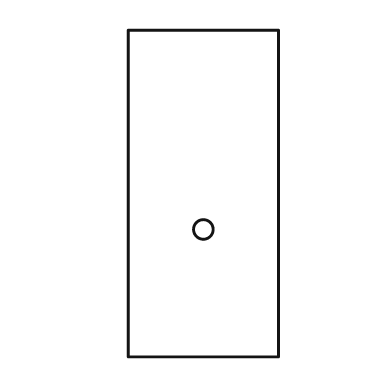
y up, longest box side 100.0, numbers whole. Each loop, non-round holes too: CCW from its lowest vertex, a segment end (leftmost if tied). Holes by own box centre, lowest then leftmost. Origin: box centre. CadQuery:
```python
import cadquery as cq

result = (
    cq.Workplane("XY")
    .moveTo(-23.0, -50.0)
    .lineTo(23.0, -50.0)
    .lineTo(23.0, 50.0)
    .lineTo(-23.0, 50.0)
    .close()
    .moveTo(0.0, -11.0)
    .circle(3.0)
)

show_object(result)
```